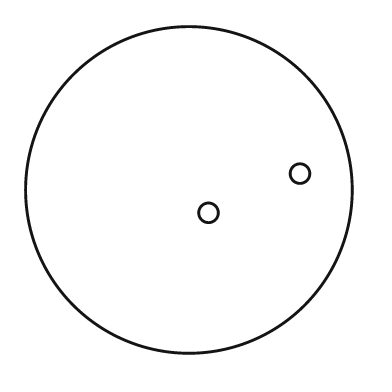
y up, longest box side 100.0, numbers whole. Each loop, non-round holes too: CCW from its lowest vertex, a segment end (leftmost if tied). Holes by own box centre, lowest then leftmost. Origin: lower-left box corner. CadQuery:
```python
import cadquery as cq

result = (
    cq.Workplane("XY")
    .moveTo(50.0, 50.0)
    .circle(50.0)
    .moveTo(56.0, 43.0)
    .circle(3.0)
    .moveTo(84.0, 55.0)
    .circle(3.0)
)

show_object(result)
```